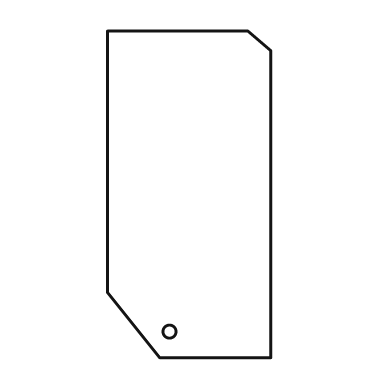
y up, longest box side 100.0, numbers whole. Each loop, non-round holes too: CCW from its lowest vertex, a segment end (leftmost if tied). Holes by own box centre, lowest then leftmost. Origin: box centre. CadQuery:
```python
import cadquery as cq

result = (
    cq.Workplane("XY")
    .moveTo(-9.0, -50.0)
    .lineTo(25.0, -50.0)
    .lineTo(25.0, 44.0)
    .lineTo(18.0, 50.0)
    .lineTo(-25.0, 50.0)
    .lineTo(-25.0, -30.0)
    .close()
    .moveTo(-6.0, -42.0)
    .circle(2.0)
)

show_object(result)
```